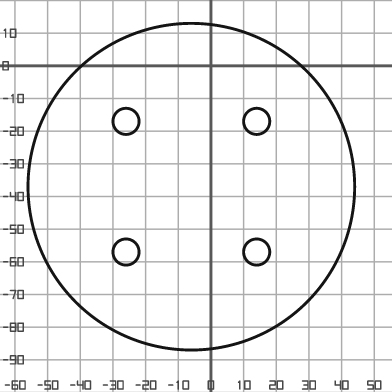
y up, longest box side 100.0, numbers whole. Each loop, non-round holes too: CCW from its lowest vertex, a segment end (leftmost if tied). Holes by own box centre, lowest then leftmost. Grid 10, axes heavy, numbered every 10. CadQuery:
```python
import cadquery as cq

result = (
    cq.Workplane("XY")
    .moveTo(-6.0, -37.0)
    .circle(50.0)
    .moveTo(-26.0, -57.0)
    .circle(4.0)
    .moveTo(14.0, -57.0)
    .circle(4.0)
    .moveTo(-26.0, -17.0)
    .circle(4.0)
    .moveTo(14.0, -17.0)
    .circle(4.0)
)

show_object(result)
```